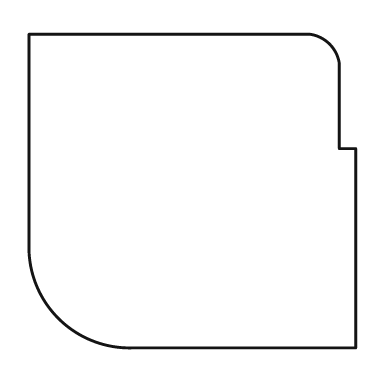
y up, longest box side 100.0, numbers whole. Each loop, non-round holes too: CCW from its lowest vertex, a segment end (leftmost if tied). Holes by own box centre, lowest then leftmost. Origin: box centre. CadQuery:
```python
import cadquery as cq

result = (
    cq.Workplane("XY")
    .moveTo(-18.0, -48.0)
    .lineTo(50.0, -48.0)
    .lineTo(50.0, 13.0)
    .lineTo(45.0, 13.0)
    .lineTo(45.0, 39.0)
    .threePointArc((42.0, 45.0), (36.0, 48.0))
    .lineTo(-50.0, 48.0)
    .lineTo(-50.0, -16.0)
    .threePointArc((-41.0, -39.0), (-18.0, -48.0))
    .close()
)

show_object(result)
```